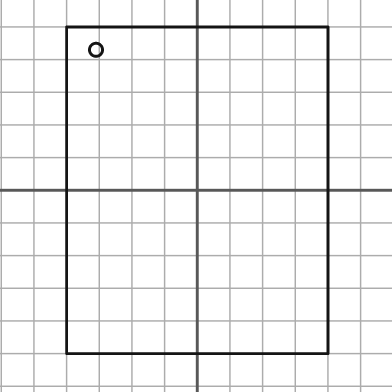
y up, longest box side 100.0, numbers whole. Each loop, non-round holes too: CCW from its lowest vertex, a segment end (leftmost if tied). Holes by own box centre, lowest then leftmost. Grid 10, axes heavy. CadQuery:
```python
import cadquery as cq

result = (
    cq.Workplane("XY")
    .moveTo(-40.0, -50.0)
    .lineTo(40.0, -50.0)
    .lineTo(40.0, 50.0)
    .lineTo(-40.0, 50.0)
    .close()
    .moveTo(-31.0, 43.0)
    .circle(2.0)
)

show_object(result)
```